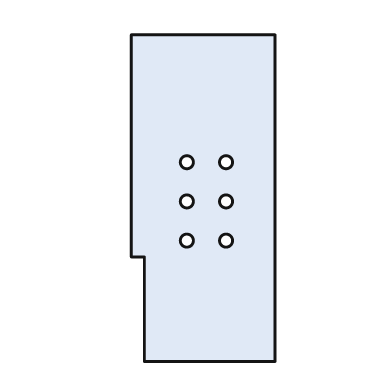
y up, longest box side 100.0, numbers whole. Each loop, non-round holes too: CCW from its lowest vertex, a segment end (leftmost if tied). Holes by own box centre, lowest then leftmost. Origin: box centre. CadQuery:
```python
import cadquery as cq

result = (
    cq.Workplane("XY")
    .moveTo(-18.0, -50.0)
    .lineTo(22.0, -50.0)
    .lineTo(22.0, 50.0)
    .lineTo(-22.0, 50.0)
    .lineTo(-22.0, -18.0)
    .lineTo(-18.0, -18.0)
    .close()
    .moveTo(-5.0, -13.0)
    .circle(2.0)
    .moveTo(7.0, -13.0)
    .circle(2.0)
    .moveTo(-5.0, -1.0)
    .circle(2.0)
    .moveTo(7.0, -1.0)
    .circle(2.0)
    .moveTo(-5.0, 11.0)
    .circle(2.0)
    .moveTo(7.0, 11.0)
    .circle(2.0)
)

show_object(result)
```